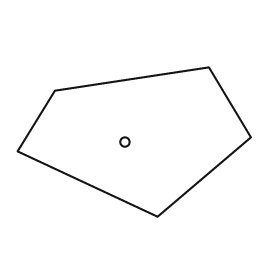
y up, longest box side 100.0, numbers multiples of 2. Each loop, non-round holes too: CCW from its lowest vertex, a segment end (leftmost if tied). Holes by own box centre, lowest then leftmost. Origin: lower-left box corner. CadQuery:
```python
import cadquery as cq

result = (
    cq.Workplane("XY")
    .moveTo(60.0, 0.0)
    .lineTo(100.0, 34.0)
    .lineTo(82.0, 64.0)
    .lineTo(16.0, 54.0)
    .lineTo(0.0, 28.0)
    .close()
    .moveTo(46.0, 32.0)
    .circle(2.0)
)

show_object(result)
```